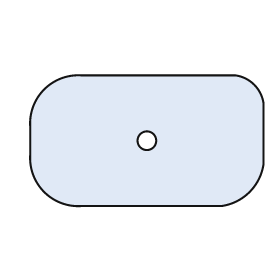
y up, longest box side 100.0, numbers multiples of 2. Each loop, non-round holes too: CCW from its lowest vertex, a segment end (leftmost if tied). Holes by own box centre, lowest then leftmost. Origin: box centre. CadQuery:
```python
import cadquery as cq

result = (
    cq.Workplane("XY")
    .moveTo(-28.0, -28.0)
    .lineTo(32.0, -28.0)
    .threePointArc((44.0, -22.0), (50.0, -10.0))
    .lineTo(50.0, 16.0)
    .threePointArc((46.0, 24.0), (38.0, 28.0))
    .lineTo(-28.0, 28.0)
    .threePointArc((-44.0, 22.0), (-50.0, 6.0))
    .lineTo(-50.0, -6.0)
    .threePointArc((-44.0, -22.0), (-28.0, -28.0))
    .close()
    .moveTo(0.0, 0.0)
    .circle(4.0)
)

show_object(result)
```